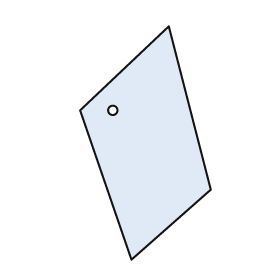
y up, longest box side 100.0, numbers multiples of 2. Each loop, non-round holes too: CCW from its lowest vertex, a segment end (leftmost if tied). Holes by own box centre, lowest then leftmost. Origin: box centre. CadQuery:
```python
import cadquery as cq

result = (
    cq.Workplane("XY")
    .moveTo(-6.0, -50.0)
    .lineTo(28.0, -20.0)
    .lineTo(10.0, 50.0)
    .lineTo(-28.0, 14.0)
    .close()
    .moveTo(-14.0, 14.0)
    .circle(2.0)
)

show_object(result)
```